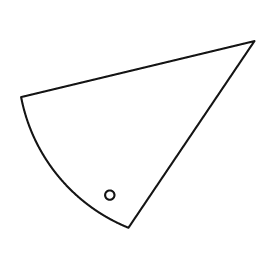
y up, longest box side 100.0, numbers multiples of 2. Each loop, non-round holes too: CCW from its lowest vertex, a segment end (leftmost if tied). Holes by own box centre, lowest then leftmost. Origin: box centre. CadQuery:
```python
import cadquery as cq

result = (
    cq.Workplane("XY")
    .moveTo(-4.0, -40.0)
    .lineTo(50.0, 40.0)
    .lineTo(-50.0, 16.0)
    .threePointArc((-34.0, -18.0), (-4.0, -40.0))
    .close()
    .moveTo(-12.0, -26.0)
    .circle(2.0)
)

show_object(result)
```